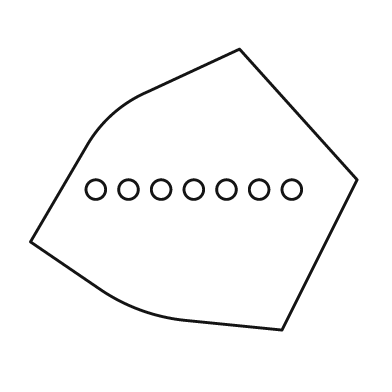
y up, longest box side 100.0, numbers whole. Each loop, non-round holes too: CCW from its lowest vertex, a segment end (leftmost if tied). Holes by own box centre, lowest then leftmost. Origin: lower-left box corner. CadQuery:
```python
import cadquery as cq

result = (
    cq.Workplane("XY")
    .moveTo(77.0, 0.0)
    .lineTo(100.0, 46.0)
    .lineTo(64.0, 86.0)
    .lineTo(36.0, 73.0)
    .threePointArc((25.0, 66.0), (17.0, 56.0))
    .lineTo(0.0, 27.0)
    .lineTo(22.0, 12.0)
    .threePointArc((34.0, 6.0), (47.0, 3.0))
    .close()
    .moveTo(20.0, 43.0)
    .circle(3.0)
    .moveTo(30.0, 43.0)
    .circle(3.0)
    .moveTo(40.0, 43.0)
    .circle(3.0)
    .moveTo(50.0, 43.0)
    .circle(3.0)
    .moveTo(60.0, 43.0)
    .circle(3.0)
    .moveTo(70.0, 43.0)
    .circle(3.0)
    .moveTo(80.0, 43.0)
    .circle(3.0)
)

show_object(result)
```